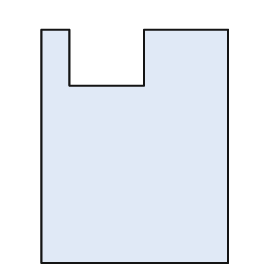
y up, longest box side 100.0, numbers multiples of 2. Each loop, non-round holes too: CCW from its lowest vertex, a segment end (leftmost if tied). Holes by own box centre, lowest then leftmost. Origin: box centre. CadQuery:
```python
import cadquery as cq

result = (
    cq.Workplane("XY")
    .moveTo(-40.0, -50.0)
    .lineTo(40.0, -50.0)
    .lineTo(40.0, 50.0)
    .lineTo(4.0, 50.0)
    .lineTo(4.0, 26.0)
    .lineTo(-28.0, 26.0)
    .lineTo(-28.0, 50.0)
    .lineTo(-40.0, 50.0)
    .close()
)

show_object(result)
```